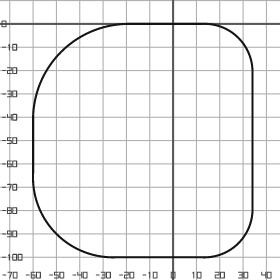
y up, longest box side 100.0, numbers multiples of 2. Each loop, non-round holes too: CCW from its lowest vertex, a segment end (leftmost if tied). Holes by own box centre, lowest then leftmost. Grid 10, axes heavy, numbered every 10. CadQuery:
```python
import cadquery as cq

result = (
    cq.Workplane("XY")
    .moveTo(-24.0, -100.0)
    .lineTo(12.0, -100.0)
    .threePointArc((28.0, -94.0), (34.0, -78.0))
    .lineTo(34.0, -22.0)
    .threePointArc((28.0, -6.0), (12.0, 0.0))
    .lineTo(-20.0, 0.0)
    .threePointArc((-48.0, -12.0), (-60.0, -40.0))
    .lineTo(-60.0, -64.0)
    .threePointArc((-50.0, -90.0), (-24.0, -100.0))
    .close()
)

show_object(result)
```